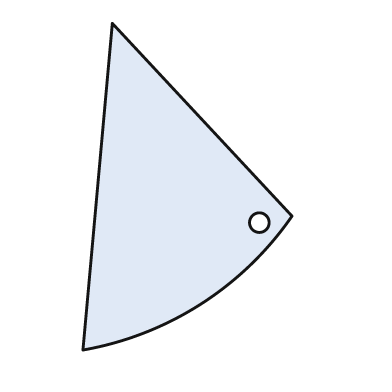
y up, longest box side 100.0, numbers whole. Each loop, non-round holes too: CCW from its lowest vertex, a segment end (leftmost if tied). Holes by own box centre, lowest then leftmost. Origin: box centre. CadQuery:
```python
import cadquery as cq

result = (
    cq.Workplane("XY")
    .moveTo(-32.0, -50.0)
    .threePointArc((4.0, -36.0), (32.0, -9.0))
    .lineTo(-23.0, 50.0)
    .close()
    .moveTo(22.0, -11.0)
    .circle(3.0)
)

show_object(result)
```